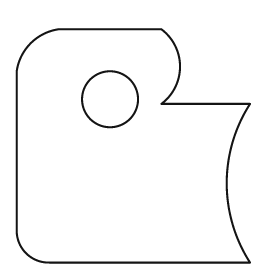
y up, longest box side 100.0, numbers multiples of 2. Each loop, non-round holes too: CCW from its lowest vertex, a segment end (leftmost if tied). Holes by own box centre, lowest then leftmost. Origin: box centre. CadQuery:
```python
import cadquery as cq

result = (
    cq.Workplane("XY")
    .moveTo(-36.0, -50.0)
    .lineTo(50.0, -50.0)
    .threePointArc((40.0, -16.0), (50.0, 18.0))
    .lineTo(12.0, 18.0)
    .threePointArc((20.0, 34.0), (12.0, 50.0))
    .lineTo(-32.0, 50.0)
    .threePointArc((-44.0, 44.0), (-50.0, 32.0))
    .lineTo(-50.0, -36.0)
    .threePointArc((-46.0, -46.0), (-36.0, -50.0))
    .close()
    .moveTo(-10.0, 20.0)
    .circle(12.0)
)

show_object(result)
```